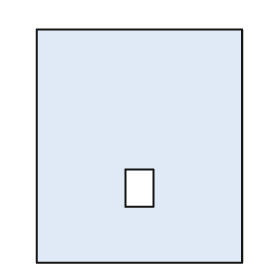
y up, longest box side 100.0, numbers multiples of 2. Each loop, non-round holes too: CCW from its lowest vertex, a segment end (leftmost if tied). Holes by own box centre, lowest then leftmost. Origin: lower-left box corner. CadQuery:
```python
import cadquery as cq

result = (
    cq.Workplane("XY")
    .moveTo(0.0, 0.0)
    .lineTo(88.0, 0.0)
    .lineTo(88.0, 100.0)
    .lineTo(0.0, 100.0)
    .close()
    .moveTo(38.0, 24.0)
    .lineTo(50.0, 24.0)
    .lineTo(50.0, 40.0)
    .lineTo(38.0, 40.0)
    .close()
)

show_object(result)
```